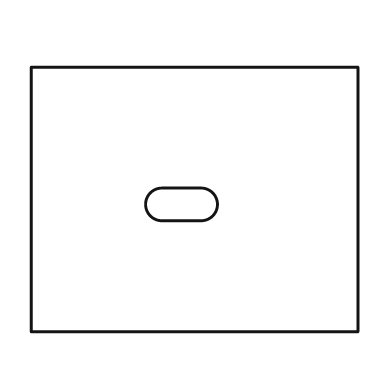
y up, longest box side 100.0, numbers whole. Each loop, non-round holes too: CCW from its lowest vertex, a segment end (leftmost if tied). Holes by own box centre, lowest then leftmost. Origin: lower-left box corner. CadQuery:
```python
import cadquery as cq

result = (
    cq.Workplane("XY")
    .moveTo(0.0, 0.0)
    .lineTo(100.0, 0.0)
    .lineTo(100.0, 81.0)
    .lineTo(0.0, 81.0)
    .close()
    .moveTo(40.0, 34.0)
    .lineTo(52.0, 34.0)
    .threePointArc((57.0, 39.0), (52.0, 44.0))
    .lineTo(40.0, 44.0)
    .threePointArc((35.0, 39.0), (40.0, 34.0))
    .close()
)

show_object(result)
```